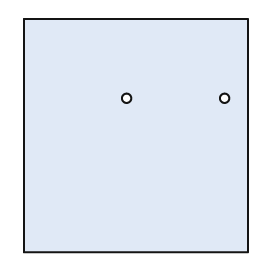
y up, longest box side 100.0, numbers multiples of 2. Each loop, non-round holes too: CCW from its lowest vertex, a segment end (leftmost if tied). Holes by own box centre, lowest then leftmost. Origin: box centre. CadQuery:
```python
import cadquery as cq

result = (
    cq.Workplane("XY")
    .moveTo(-48.0, -50.0)
    .lineTo(48.0, -50.0)
    .lineTo(48.0, 50.0)
    .lineTo(-48.0, 50.0)
    .close()
    .moveTo(-4.0, 16.0)
    .circle(2.0)
    .moveTo(38.0, 16.0)
    .circle(2.0)
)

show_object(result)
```